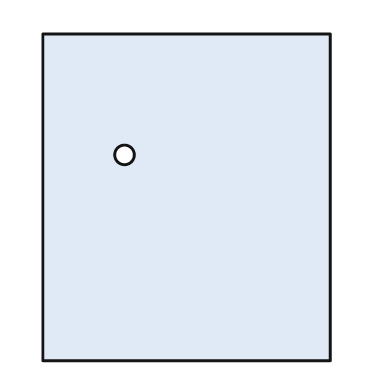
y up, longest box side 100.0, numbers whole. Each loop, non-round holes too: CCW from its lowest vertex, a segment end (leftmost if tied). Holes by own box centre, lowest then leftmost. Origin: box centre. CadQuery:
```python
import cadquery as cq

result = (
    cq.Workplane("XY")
    .moveTo(-44.0, -50.0)
    .lineTo(44.0, -50.0)
    .lineTo(44.0, 50.0)
    .lineTo(-44.0, 50.0)
    .close()
    .moveTo(-19.0, 13.0)
    .circle(3.0)
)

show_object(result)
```